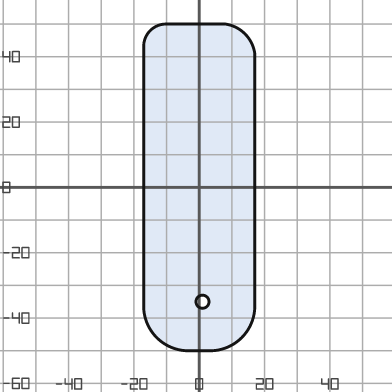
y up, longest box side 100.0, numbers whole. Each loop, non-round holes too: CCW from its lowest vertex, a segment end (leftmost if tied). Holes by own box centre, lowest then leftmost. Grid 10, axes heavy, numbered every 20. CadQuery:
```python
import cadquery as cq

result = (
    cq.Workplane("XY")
    .moveTo(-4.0, -50.0)
    .lineTo(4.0, -50.0)
    .threePointArc((13.0, -46.0), (17.0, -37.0))
    .lineTo(17.0, 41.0)
    .threePointArc((14.0, 47.0), (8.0, 50.0))
    .lineTo(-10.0, 50.0)
    .threePointArc((-15.0, 48.0), (-17.0, 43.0))
    .lineTo(-17.0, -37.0)
    .threePointArc((-13.0, -46.0), (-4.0, -50.0))
    .close()
    .moveTo(1.0, -35.0)
    .circle(2.0)
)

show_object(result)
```